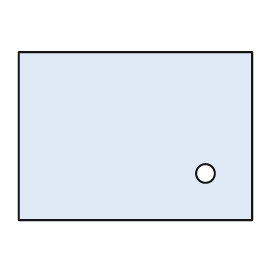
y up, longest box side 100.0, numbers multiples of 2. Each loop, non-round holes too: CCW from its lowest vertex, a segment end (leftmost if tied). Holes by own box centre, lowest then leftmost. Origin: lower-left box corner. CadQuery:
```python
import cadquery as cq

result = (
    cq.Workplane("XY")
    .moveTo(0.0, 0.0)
    .lineTo(100.0, 0.0)
    .lineTo(100.0, 72.0)
    .lineTo(0.0, 72.0)
    .close()
    .moveTo(80.0, 20.0)
    .circle(4.0)
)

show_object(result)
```